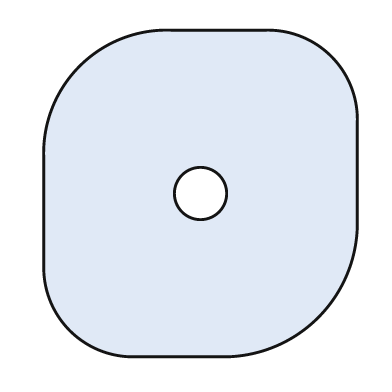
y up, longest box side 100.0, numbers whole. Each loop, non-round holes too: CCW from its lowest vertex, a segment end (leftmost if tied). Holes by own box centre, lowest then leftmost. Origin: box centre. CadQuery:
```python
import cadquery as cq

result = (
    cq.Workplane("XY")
    .moveTo(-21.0, -50.0)
    .lineTo(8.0, -50.0)
    .threePointArc((36.0, -38.0), (48.0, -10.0))
    .lineTo(48.0, 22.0)
    .threePointArc((40.0, 42.0), (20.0, 50.0))
    .lineTo(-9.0, 50.0)
    .threePointArc((-37.0, 39.0), (-48.0, 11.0))
    .lineTo(-48.0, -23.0)
    .threePointArc((-40.0, -42.0), (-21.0, -50.0))
    .close()
    .moveTo(0.0, 0.0)
    .circle(8.0)
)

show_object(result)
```